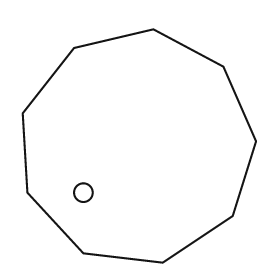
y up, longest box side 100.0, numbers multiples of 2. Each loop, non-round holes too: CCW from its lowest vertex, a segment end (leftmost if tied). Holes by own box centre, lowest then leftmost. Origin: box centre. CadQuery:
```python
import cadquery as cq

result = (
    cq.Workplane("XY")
    .moveTo(10.0, -50.0)
    .lineTo(40.0, -30.0)
    .lineTo(50.0, 2.0)
    .lineTo(36.0, 34.0)
    .lineTo(6.0, 50.0)
    .lineTo(-28.0, 42.0)
    .lineTo(-50.0, 14.0)
    .lineTo(-48.0, -20.0)
    .lineTo(-24.0, -46.0)
    .close()
    .moveTo(-24.0, -20.0)
    .circle(4.0)
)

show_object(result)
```